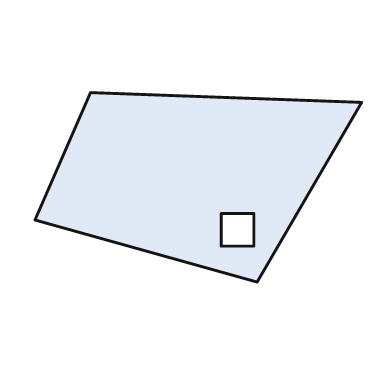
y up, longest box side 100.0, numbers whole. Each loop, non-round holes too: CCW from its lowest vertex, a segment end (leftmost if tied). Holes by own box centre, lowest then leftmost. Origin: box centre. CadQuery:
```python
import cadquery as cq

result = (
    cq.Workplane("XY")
    .moveTo(18.0, -29.0)
    .lineTo(50.0, 26.0)
    .lineTo(-33.0, 29.0)
    .lineTo(-50.0, -10.0)
    .close()
    .moveTo(7.0, -18.0)
    .lineTo(17.0, -18.0)
    .lineTo(17.0, -8.0)
    .lineTo(7.0, -8.0)
    .close()
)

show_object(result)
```